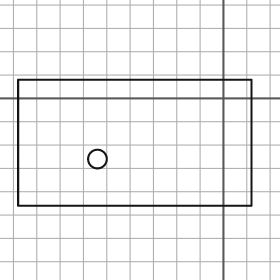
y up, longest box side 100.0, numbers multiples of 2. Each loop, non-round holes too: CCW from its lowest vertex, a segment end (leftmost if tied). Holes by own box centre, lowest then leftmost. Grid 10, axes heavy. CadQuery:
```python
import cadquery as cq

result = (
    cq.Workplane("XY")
    .moveTo(-88.0, -46.0)
    .lineTo(12.0, -46.0)
    .lineTo(12.0, 8.0)
    .lineTo(-88.0, 8.0)
    .close()
    .moveTo(-54.0, -26.0)
    .circle(4.0)
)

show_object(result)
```